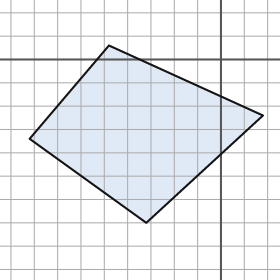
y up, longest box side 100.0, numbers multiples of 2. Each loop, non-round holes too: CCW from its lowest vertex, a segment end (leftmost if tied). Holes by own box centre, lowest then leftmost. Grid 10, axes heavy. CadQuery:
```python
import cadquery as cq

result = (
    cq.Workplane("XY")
    .moveTo(-32.0, -70.0)
    .lineTo(18.0, -24.0)
    .lineTo(-48.0, 6.0)
    .lineTo(-82.0, -34.0)
    .close()
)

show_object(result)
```